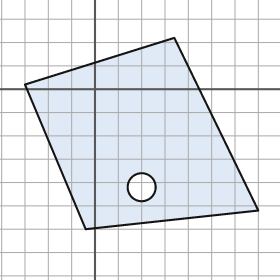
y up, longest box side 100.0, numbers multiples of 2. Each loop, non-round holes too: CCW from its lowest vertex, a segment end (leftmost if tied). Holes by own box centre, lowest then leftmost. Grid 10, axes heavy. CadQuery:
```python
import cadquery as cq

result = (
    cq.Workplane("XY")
    .moveTo(-4.0, -60.0)
    .lineTo(70.0, -52.0)
    .lineTo(34.0, 22.0)
    .lineTo(-30.0, 2.0)
    .close()
    .moveTo(20.0, -42.0)
    .circle(6.0)
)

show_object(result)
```